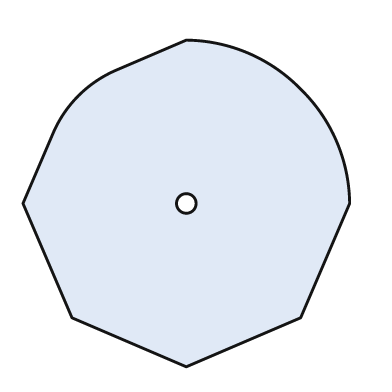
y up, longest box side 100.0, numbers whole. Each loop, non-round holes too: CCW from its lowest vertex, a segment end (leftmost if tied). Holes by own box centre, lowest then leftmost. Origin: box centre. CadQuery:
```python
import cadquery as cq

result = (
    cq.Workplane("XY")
    .moveTo(0.0, -50.0)
    .lineTo(35.0, -35.0)
    .lineTo(50.0, 0.0)
    .threePointArc((46.0, 19.0), (35.0, 35.0))
    .threePointArc((19.0, 46.0), (0.0, 50.0))
    .lineTo(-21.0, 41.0)
    .threePointArc((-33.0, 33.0), (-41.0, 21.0))
    .lineTo(-50.0, 0.0)
    .lineTo(-35.0, -35.0)
    .close()
    .moveTo(0.0, 0.0)
    .circle(3.0)
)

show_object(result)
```